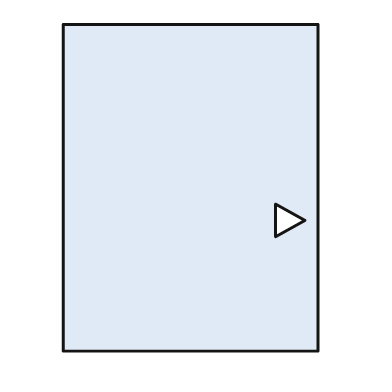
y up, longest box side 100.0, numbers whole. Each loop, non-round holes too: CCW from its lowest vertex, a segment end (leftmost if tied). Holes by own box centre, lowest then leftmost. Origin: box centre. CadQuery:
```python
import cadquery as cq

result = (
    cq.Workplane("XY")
    .moveTo(-39.0, -50.0)
    .lineTo(39.0, -50.0)
    .lineTo(39.0, 50.0)
    .lineTo(-39.0, 50.0)
    .close()
    .moveTo(26.0, -15.0)
    .lineTo(35.0, -10.0)
    .lineTo(26.0, -5.0)
    .close()
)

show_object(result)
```